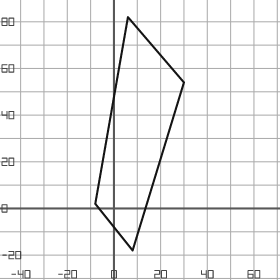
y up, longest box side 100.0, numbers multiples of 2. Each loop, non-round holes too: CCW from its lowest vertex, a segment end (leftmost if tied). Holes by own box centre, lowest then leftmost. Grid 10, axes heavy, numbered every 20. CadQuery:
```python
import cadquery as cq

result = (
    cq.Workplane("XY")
    .moveTo(8.0, -18.0)
    .lineTo(30.0, 54.0)
    .lineTo(6.0, 82.0)
    .lineTo(-8.0, 2.0)
    .close()
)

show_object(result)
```